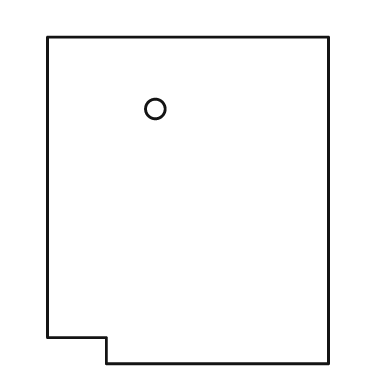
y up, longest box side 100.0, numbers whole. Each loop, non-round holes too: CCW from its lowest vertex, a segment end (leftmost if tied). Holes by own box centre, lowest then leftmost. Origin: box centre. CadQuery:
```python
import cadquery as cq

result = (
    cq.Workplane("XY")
    .moveTo(-25.0, -50.0)
    .lineTo(43.0, -50.0)
    .lineTo(43.0, 50.0)
    .lineTo(-43.0, 50.0)
    .lineTo(-43.0, -42.0)
    .lineTo(-25.0, -42.0)
    .close()
    .moveTo(-10.0, 28.0)
    .circle(3.0)
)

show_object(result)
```